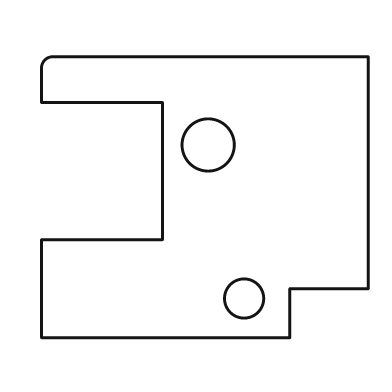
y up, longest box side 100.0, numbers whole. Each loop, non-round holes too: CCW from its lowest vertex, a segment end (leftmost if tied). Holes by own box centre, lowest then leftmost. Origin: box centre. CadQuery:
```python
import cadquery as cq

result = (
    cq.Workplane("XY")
    .moveTo(-50.0, -43.0)
    .lineTo(26.0, -43.0)
    .lineTo(26.0, -28.0)
    .lineTo(50.0, -28.0)
    .lineTo(50.0, 43.0)
    .lineTo(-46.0, 43.0)
    .threePointArc((-49.0, 42.0), (-50.0, 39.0))
    .lineTo(-50.0, 29.0)
    .lineTo(-13.0, 29.0)
    .lineTo(-13.0, -13.0)
    .lineTo(-50.0, -13.0)
    .close()
    .moveTo(12.0, -31.0)
    .circle(6.0)
    .moveTo(1.0, 16.0)
    .circle(8.0)
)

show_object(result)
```